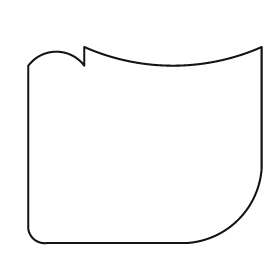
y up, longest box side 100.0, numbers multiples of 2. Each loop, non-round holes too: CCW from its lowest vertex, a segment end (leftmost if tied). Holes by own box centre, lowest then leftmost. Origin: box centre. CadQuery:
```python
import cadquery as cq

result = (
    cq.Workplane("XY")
    .moveTo(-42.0, -42.0)
    .lineTo(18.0, -42.0)
    .threePointArc((40.0, -32.0), (50.0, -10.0))
    .lineTo(50.0, 42.0)
    .threePointArc((12.0, 34.0), (-26.0, 42.0))
    .lineTo(-26.0, 34.0)
    .threePointArc((-38.0, 40.0), (-50.0, 34.0))
    .lineTo(-50.0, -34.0)
    .threePointArc((-48.0, -40.0), (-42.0, -42.0))
    .close()
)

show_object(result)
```